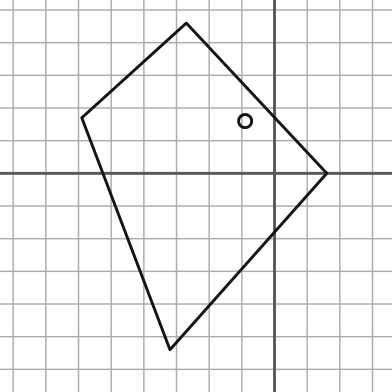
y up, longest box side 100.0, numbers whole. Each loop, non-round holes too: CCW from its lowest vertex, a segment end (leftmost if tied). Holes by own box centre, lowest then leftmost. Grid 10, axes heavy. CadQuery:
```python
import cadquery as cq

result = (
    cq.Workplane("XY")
    .moveTo(-32.0, -54.0)
    .lineTo(16.0, 0.0)
    .lineTo(-27.0, 46.0)
    .lineTo(-59.0, 17.0)
    .close()
    .moveTo(-9.0, 16.0)
    .circle(2.0)
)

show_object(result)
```